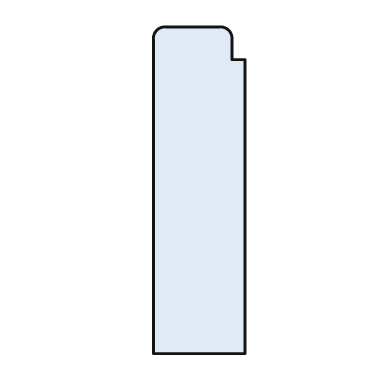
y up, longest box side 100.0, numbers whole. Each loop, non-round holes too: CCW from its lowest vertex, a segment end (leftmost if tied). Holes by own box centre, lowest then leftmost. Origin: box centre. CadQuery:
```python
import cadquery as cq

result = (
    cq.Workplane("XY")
    .moveTo(-14.0, -50.0)
    .lineTo(14.0, -50.0)
    .lineTo(14.0, 40.0)
    .lineTo(10.0, 40.0)
    .lineTo(10.0, 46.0)
    .threePointArc((9.0, 49.0), (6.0, 50.0))
    .lineTo(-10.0, 50.0)
    .threePointArc((-13.0, 49.0), (-14.0, 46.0))
    .close()
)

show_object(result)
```